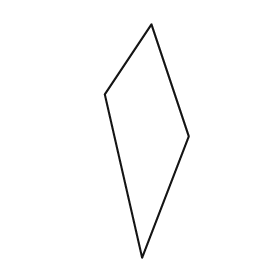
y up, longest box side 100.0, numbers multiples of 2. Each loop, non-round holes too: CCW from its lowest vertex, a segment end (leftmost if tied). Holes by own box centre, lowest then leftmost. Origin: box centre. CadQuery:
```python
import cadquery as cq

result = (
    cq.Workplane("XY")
    .moveTo(-2.0, -50.0)
    .lineTo(18.0, 2.0)
    .lineTo(2.0, 50.0)
    .lineTo(-18.0, 20.0)
    .close()
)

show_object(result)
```